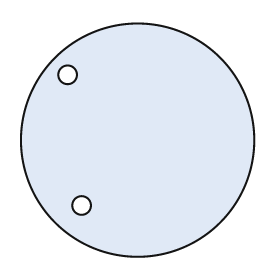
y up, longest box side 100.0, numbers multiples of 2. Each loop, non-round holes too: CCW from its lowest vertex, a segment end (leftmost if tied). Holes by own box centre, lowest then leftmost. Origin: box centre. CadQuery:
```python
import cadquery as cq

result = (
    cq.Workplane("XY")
    .moveTo(0.0, 0.0)
    .circle(50.0)
    .moveTo(-24.0, -28.0)
    .circle(4.0)
    .moveTo(-30.0, 28.0)
    .circle(4.0)
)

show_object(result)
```